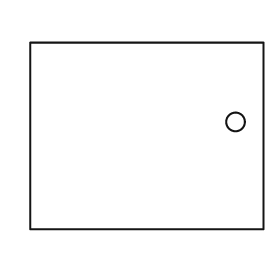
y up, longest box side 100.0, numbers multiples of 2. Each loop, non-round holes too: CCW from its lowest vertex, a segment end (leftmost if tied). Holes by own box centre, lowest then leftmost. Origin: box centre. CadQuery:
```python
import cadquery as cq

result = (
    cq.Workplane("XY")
    .moveTo(-50.0, -40.0)
    .lineTo(50.0, -40.0)
    .lineTo(50.0, 40.0)
    .lineTo(-50.0, 40.0)
    .close()
    .moveTo(38.0, 6.0)
    .circle(4.0)
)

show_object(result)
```